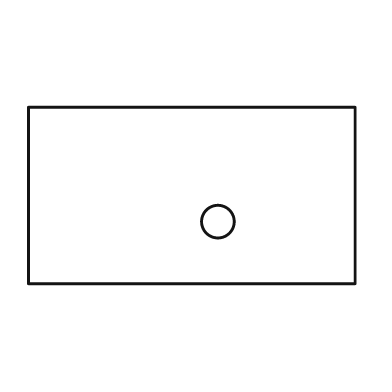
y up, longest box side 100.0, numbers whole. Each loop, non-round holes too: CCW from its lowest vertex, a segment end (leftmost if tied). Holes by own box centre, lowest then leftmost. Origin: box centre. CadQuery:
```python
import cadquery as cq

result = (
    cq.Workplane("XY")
    .moveTo(-50.0, -27.0)
    .lineTo(50.0, -27.0)
    .lineTo(50.0, 27.0)
    .lineTo(-50.0, 27.0)
    .close()
    .moveTo(8.0, -8.0)
    .circle(5.0)
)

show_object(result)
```